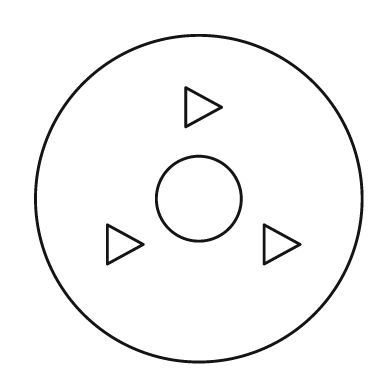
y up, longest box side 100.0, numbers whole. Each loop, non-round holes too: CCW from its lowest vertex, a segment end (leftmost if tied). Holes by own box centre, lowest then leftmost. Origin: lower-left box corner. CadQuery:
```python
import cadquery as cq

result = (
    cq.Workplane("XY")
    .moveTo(50.0, 50.0)
    .circle(50.0)
    .moveTo(22.0, 30.0)
    .lineTo(33.0, 36.0)
    .lineTo(22.0, 42.0)
    .close()
    .moveTo(70.0, 30.0)
    .lineTo(81.0, 36.0)
    .lineTo(70.0, 42.0)
    .close()
    .moveTo(50.0, 50.0)
    .circle(13.0)
    .moveTo(46.0, 72.0)
    .lineTo(57.0, 78.0)
    .lineTo(46.0, 84.0)
    .close()
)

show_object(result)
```